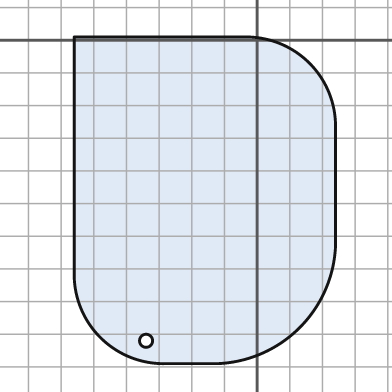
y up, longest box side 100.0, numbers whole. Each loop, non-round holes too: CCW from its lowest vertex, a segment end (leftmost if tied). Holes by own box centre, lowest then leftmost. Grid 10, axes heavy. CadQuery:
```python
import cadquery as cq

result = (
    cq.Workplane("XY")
    .moveTo(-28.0, -99.0)
    .lineTo(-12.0, -99.0)
    .threePointArc((13.0, -88.0), (24.0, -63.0))
    .lineTo(24.0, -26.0)
    .threePointArc((16.0, -7.0), (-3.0, 1.0))
    .lineTo(-56.0, 1.0)
    .lineTo(-56.0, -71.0)
    .threePointArc((-48.0, -91.0), (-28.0, -99.0))
    .close()
    .moveTo(-34.0, -92.0)
    .circle(2.0)
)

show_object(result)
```